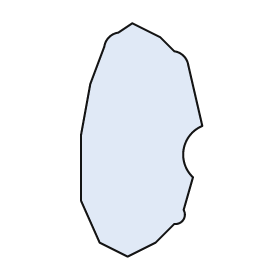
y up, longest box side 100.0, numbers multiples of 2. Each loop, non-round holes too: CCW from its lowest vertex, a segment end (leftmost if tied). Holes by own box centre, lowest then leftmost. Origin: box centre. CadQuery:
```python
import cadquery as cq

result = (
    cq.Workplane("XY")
    .moveTo(-6.0, -50.0)
    .lineTo(6.0, -44.0)
    .lineTo(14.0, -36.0)
    .threePointArc((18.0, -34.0), (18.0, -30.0))
    .lineTo(22.0, -16.0)
    .threePointArc((18.0, -4.0), (26.0, 6.0))
    .lineTo(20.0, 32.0)
    .threePointArc((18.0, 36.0), (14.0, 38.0))
    .lineTo(8.0, 44.0)
    .lineTo(-4.0, 50.0)
    .lineTo(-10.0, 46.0)
    .threePointArc((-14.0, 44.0), (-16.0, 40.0))
    .lineTo(-22.0, 24.0)
    .lineTo(-26.0, 2.0)
    .lineTo(-26.0, -26.0)
    .lineTo(-18.0, -44.0)
    .close()
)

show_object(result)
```